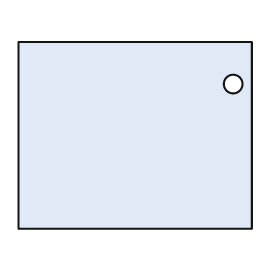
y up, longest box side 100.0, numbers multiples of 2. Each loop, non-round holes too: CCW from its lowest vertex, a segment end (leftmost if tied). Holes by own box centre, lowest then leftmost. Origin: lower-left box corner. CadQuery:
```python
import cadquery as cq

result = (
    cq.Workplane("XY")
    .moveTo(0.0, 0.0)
    .lineTo(100.0, 0.0)
    .lineTo(100.0, 80.0)
    .lineTo(0.0, 80.0)
    .close()
    .moveTo(92.0, 62.0)
    .circle(4.0)
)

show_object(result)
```